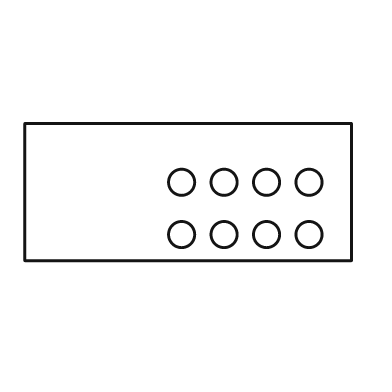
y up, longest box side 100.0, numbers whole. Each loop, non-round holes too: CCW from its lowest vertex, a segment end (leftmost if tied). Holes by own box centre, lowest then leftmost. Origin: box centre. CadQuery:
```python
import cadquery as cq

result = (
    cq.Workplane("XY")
    .moveTo(-50.0, -21.0)
    .lineTo(50.0, -21.0)
    .lineTo(50.0, 21.0)
    .lineTo(-50.0, 21.0)
    .close()
    .moveTo(-2.0, -13.0)
    .circle(4.0)
    .moveTo(11.0, -13.0)
    .circle(4.0)
    .moveTo(24.0, -13.0)
    .circle(4.0)
    .moveTo(37.0, -13.0)
    .circle(4.0)
    .moveTo(-2.0, 3.0)
    .circle(4.0)
    .moveTo(11.0, 3.0)
    .circle(4.0)
    .moveTo(24.0, 3.0)
    .circle(4.0)
    .moveTo(37.0, 3.0)
    .circle(4.0)
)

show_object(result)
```